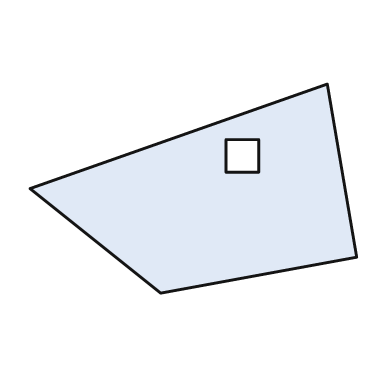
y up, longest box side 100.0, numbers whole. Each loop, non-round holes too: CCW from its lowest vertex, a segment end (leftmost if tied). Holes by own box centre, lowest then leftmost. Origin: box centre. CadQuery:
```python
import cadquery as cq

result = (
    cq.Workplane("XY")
    .moveTo(-10.0, -32.0)
    .lineTo(50.0, -21.0)
    .lineTo(41.0, 32.0)
    .lineTo(-50.0, 0.0)
    .close()
    .moveTo(10.0, 5.0)
    .lineTo(20.0, 5.0)
    .lineTo(20.0, 15.0)
    .lineTo(10.0, 15.0)
    .close()
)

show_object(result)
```